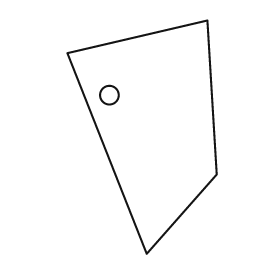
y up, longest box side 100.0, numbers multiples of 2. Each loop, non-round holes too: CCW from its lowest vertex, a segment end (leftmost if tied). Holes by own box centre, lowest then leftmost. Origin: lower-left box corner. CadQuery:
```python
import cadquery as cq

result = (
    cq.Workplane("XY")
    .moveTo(34.0, 0.0)
    .lineTo(64.0, 34.0)
    .lineTo(60.0, 100.0)
    .lineTo(0.0, 86.0)
    .close()
    .moveTo(18.0, 68.0)
    .circle(4.0)
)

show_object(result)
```